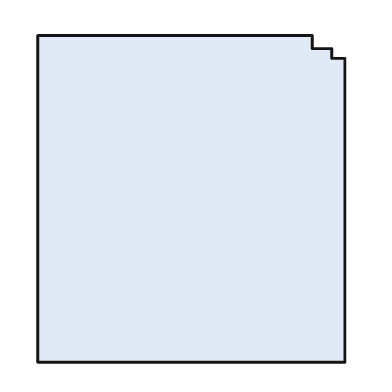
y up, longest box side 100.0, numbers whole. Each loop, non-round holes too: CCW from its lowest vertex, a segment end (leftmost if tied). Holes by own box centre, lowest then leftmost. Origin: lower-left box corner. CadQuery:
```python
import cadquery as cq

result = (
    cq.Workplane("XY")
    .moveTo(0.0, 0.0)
    .lineTo(94.0, 0.0)
    .lineTo(94.0, 93.0)
    .lineTo(90.0, 93.0)
    .lineTo(90.0, 96.0)
    .lineTo(84.0, 96.0)
    .lineTo(84.0, 100.0)
    .lineTo(0.0, 100.0)
    .close()
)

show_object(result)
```